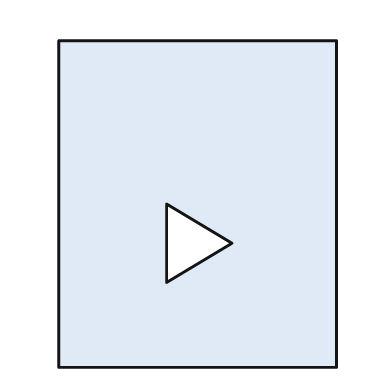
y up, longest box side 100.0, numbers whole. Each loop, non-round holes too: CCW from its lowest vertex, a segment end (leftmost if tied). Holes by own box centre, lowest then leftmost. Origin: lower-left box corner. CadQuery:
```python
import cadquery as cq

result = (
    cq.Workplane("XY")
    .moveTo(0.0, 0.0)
    .lineTo(85.0, 0.0)
    .lineTo(85.0, 100.0)
    .lineTo(0.0, 100.0)
    .close()
    .moveTo(33.0, 26.0)
    .lineTo(53.0, 38.0)
    .lineTo(33.0, 50.0)
    .close()
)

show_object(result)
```